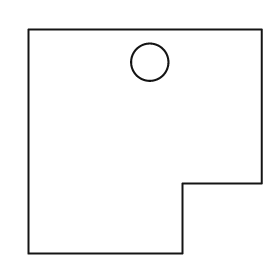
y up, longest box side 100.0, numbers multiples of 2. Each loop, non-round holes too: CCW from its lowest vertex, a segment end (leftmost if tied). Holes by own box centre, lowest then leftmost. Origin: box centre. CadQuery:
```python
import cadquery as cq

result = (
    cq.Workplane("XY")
    .moveTo(-50.0, -48.0)
    .lineTo(16.0, -48.0)
    .lineTo(16.0, -18.0)
    .lineTo(50.0, -18.0)
    .lineTo(50.0, 48.0)
    .lineTo(-50.0, 48.0)
    .close()
    .moveTo(2.0, 34.0)
    .circle(8.0)
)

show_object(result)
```